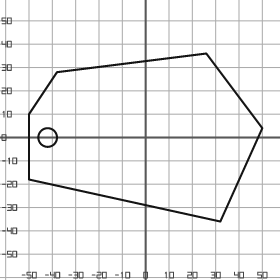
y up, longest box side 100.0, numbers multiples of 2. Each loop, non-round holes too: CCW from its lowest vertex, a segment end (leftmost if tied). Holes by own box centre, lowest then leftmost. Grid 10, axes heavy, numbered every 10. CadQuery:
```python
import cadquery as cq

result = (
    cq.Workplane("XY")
    .moveTo(32.0, -36.0)
    .lineTo(50.0, 4.0)
    .lineTo(26.0, 36.0)
    .lineTo(-38.0, 28.0)
    .lineTo(-50.0, 10.0)
    .lineTo(-50.0, -18.0)
    .close()
    .moveTo(-42.0, 0.0)
    .circle(4.0)
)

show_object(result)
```